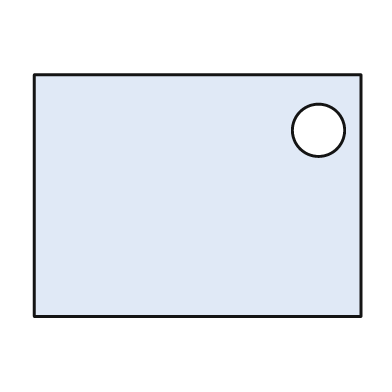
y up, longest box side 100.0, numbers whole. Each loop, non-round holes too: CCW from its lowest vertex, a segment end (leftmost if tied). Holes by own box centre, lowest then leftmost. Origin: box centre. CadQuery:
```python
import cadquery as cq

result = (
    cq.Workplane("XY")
    .moveTo(-50.0, -37.0)
    .lineTo(50.0, -37.0)
    .lineTo(50.0, 37.0)
    .lineTo(-50.0, 37.0)
    .close()
    .moveTo(37.0, 20.0)
    .circle(8.0)
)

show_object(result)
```